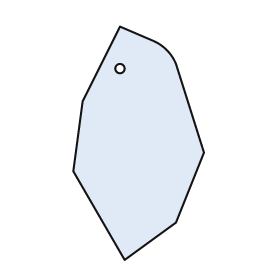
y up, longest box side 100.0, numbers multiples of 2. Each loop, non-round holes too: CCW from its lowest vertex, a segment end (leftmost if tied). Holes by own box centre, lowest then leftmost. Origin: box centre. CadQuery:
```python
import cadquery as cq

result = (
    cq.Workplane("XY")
    .moveTo(-6.0, -50.0)
    .lineTo(16.0, -34.0)
    .lineTo(28.0, -4.0)
    .lineTo(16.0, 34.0)
    .threePointArc((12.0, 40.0), (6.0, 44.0))
    .lineTo(-8.0, 50.0)
    .lineTo(-24.0, 18.0)
    .lineTo(-28.0, -12.0)
    .close()
    .moveTo(-8.0, 32.0)
    .circle(2.0)
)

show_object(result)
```